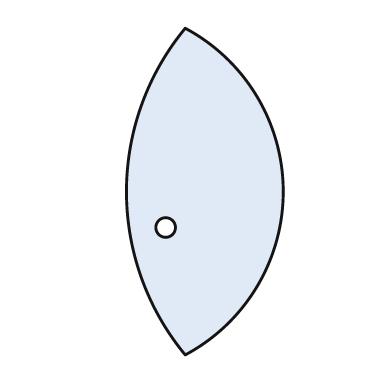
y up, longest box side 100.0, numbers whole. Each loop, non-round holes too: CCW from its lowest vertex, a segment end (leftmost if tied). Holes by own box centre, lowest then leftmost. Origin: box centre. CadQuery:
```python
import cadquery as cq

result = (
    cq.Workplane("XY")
    .moveTo(-6.0, -50.0)
    .threePointArc((24.0, 0.0), (-6.0, 50.0))
    .threePointArc((-24.0, 0.0), (-6.0, -50.0))
    .close()
    .moveTo(-12.0, -11.0)
    .circle(3.0)
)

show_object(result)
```